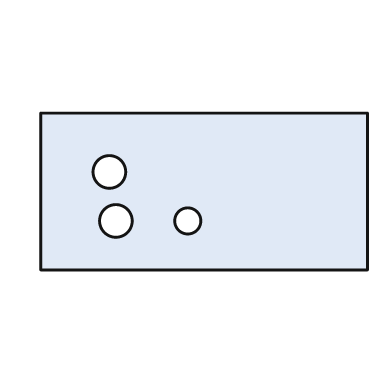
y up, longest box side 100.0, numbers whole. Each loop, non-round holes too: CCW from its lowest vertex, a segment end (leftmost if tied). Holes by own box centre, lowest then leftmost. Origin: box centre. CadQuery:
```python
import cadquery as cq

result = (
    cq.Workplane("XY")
    .moveTo(-50.0, -24.0)
    .lineTo(50.0, -24.0)
    .lineTo(50.0, 24.0)
    .lineTo(-50.0, 24.0)
    .close()
    .moveTo(-27.0, -9.0)
    .circle(5.0)
    .moveTo(-5.0, -9.0)
    .circle(4.0)
    .moveTo(-29.0, 6.0)
    .circle(5.0)
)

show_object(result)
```